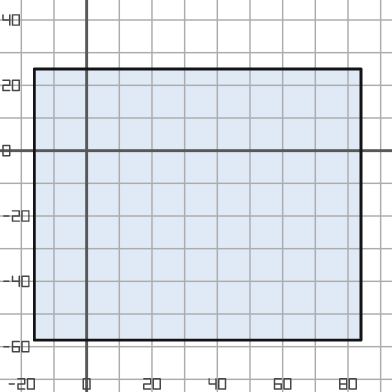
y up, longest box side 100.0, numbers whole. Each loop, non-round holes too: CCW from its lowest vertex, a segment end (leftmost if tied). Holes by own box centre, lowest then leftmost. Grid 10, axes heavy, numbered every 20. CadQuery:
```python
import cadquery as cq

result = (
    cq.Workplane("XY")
    .moveTo(-16.0, -58.0)
    .lineTo(84.0, -58.0)
    .lineTo(84.0, 25.0)
    .lineTo(-16.0, 25.0)
    .close()
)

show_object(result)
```